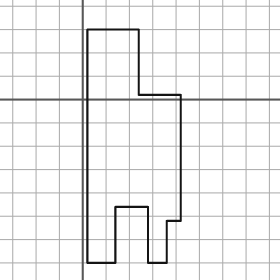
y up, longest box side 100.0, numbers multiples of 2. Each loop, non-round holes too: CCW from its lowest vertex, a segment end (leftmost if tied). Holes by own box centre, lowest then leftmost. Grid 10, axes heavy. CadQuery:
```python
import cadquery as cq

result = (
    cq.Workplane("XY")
    .moveTo(2.0, -70.0)
    .lineTo(14.0, -70.0)
    .lineTo(14.0, -46.0)
    .lineTo(28.0, -46.0)
    .lineTo(28.0, -70.0)
    .lineTo(36.0, -70.0)
    .lineTo(36.0, -52.0)
    .lineTo(42.0, -52.0)
    .lineTo(42.0, 2.0)
    .lineTo(24.0, 2.0)
    .lineTo(24.0, 30.0)
    .lineTo(2.0, 30.0)
    .close()
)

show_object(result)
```